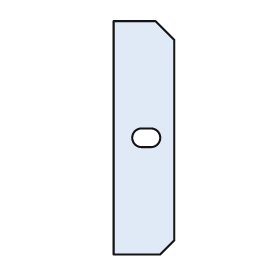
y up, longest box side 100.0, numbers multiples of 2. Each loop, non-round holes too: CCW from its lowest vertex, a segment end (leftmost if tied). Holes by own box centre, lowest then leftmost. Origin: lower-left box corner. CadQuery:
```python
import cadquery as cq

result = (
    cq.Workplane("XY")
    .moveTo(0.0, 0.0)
    .lineTo(20.0, 0.0)
    .lineTo(26.0, 6.0)
    .lineTo(26.0, 92.0)
    .lineTo(18.0, 100.0)
    .lineTo(0.0, 100.0)
    .close()
    .moveTo(12.0, 46.0)
    .lineTo(16.0, 46.0)
    .threePointArc((20.0, 50.0), (16.0, 54.0))
    .lineTo(12.0, 54.0)
    .threePointArc((8.0, 50.0), (12.0, 46.0))
    .close()
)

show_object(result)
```